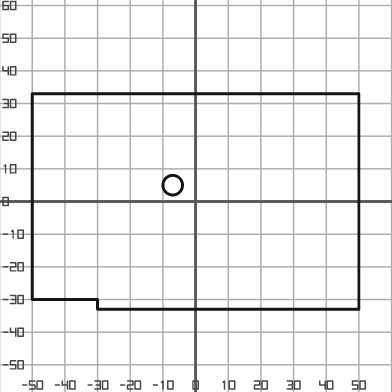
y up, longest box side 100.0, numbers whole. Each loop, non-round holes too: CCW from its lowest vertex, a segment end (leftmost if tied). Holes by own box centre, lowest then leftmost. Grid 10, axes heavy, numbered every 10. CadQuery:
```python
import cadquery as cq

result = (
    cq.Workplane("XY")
    .moveTo(-30.0, -33.0)
    .lineTo(50.0, -33.0)
    .lineTo(50.0, 33.0)
    .lineTo(-50.0, 33.0)
    .lineTo(-50.0, -30.0)
    .lineTo(-30.0, -30.0)
    .close()
    .moveTo(-7.0, 5.0)
    .circle(3.0)
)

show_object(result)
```